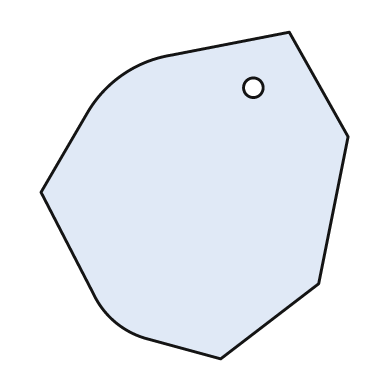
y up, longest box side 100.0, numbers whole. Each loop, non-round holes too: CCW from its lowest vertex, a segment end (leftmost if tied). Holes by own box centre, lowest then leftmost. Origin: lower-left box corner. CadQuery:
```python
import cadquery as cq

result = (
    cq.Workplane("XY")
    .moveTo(55.0, 0.0)
    .lineTo(85.0, 23.0)
    .lineTo(94.0, 68.0)
    .lineTo(76.0, 100.0)
    .lineTo(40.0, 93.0)
    .threePointArc((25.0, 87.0), (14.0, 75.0))
    .lineTo(0.0, 51.0)
    .lineTo(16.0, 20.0)
    .threePointArc((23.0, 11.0), (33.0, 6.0))
    .close()
    .moveTo(65.0, 83.0)
    .circle(3.0)
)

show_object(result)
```